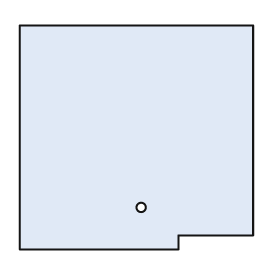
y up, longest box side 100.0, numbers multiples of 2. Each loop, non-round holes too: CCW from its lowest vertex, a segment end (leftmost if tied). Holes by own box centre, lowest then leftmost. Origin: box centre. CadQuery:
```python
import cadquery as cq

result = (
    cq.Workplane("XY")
    .moveTo(-50.0, -48.0)
    .lineTo(18.0, -48.0)
    .lineTo(18.0, -42.0)
    .lineTo(50.0, -42.0)
    .lineTo(50.0, 48.0)
    .lineTo(-50.0, 48.0)
    .close()
    .moveTo(2.0, -30.0)
    .circle(2.0)
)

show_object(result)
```